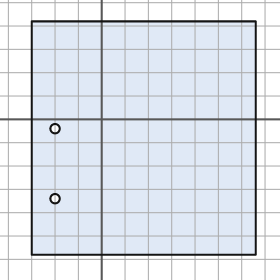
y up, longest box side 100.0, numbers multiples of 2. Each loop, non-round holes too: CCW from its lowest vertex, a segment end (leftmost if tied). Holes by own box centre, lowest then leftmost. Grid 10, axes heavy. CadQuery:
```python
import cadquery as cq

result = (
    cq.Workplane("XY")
    .moveTo(-30.0, -58.0)
    .lineTo(66.0, -58.0)
    .lineTo(66.0, 42.0)
    .lineTo(-30.0, 42.0)
    .close()
    .moveTo(-20.0, -34.0)
    .circle(2.0)
    .moveTo(-20.0, -4.0)
    .circle(2.0)
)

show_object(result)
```